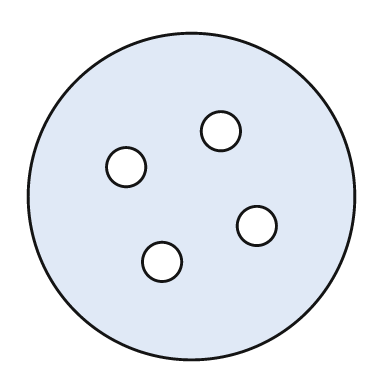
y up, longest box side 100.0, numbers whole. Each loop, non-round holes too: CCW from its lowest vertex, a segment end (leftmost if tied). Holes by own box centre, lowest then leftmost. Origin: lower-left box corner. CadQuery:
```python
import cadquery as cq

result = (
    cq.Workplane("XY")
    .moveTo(50.0, 50.0)
    .circle(50.0)
    .moveTo(41.0, 30.0)
    .circle(6.0)
    .moveTo(70.0, 41.0)
    .circle(6.0)
    .moveTo(30.0, 59.0)
    .circle(6.0)
    .moveTo(59.0, 70.0)
    .circle(6.0)
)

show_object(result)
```